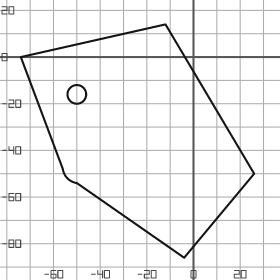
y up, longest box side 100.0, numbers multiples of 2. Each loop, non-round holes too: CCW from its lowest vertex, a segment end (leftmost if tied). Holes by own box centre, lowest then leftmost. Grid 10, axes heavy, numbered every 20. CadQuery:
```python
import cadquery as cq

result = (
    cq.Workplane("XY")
    .moveTo(-4.0, -86.0)
    .lineTo(26.0, -50.0)
    .lineTo(-12.0, 14.0)
    .lineTo(-74.0, 0.0)
    .lineTo(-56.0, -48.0)
    .threePointArc((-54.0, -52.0), (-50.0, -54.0))
    .close()
    .moveTo(-50.0, -16.0)
    .circle(4.0)
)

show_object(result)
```